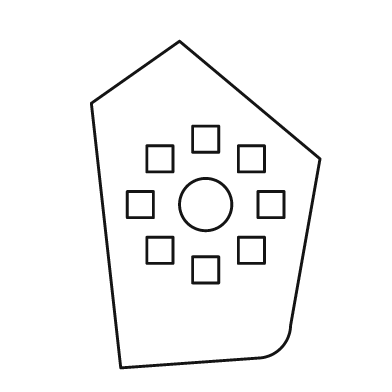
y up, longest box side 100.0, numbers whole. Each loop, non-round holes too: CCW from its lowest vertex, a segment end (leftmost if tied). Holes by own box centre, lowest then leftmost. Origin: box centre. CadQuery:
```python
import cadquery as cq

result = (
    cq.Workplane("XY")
    .moveTo(-26.0, -50.0)
    .lineTo(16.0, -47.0)
    .threePointArc((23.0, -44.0), (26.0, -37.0))
    .lineTo(35.0, 14.0)
    .lineTo(-8.0, 50.0)
    .lineTo(-35.0, 31.0)
    .close()
    .moveTo(-4.0, -24.0)
    .lineTo(4.0, -24.0)
    .lineTo(4.0, -16.0)
    .lineTo(-4.0, -16.0)
    .close()
    .moveTo(-18.0, -18.0)
    .lineTo(-10.0, -18.0)
    .lineTo(-10.0, -10.0)
    .lineTo(-18.0, -10.0)
    .close()
    .moveTo(10.0, -18.0)
    .lineTo(18.0, -18.0)
    .lineTo(18.0, -10.0)
    .lineTo(10.0, -10.0)
    .close()
    .moveTo(-24.0, -4.0)
    .lineTo(-16.0, -4.0)
    .lineTo(-16.0, 4.0)
    .lineTo(-24.0, 4.0)
    .close()
    .moveTo(0.0, 0.0)
    .circle(8.0)
    .moveTo(16.0, -4.0)
    .lineTo(24.0, -4.0)
    .lineTo(24.0, 4.0)
    .lineTo(16.0, 4.0)
    .close()
    .moveTo(-18.0, 10.0)
    .lineTo(-10.0, 10.0)
    .lineTo(-10.0, 18.0)
    .lineTo(-18.0, 18.0)
    .close()
    .moveTo(10.0, 10.0)
    .lineTo(18.0, 10.0)
    .lineTo(18.0, 18.0)
    .lineTo(10.0, 18.0)
    .close()
    .moveTo(-4.0, 16.0)
    .lineTo(4.0, 16.0)
    .lineTo(4.0, 24.0)
    .lineTo(-4.0, 24.0)
    .close()
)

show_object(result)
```